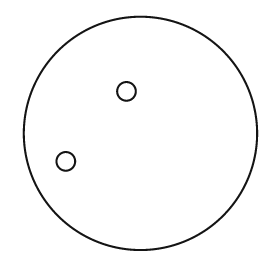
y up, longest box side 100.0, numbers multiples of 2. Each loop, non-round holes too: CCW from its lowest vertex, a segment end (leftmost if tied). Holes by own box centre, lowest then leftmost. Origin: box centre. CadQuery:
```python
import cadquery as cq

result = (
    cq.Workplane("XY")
    .moveTo(0.0, 0.0)
    .circle(50.0)
    .moveTo(-32.0, -12.0)
    .circle(4.0)
    .moveTo(-6.0, 18.0)
    .circle(4.0)
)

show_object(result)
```